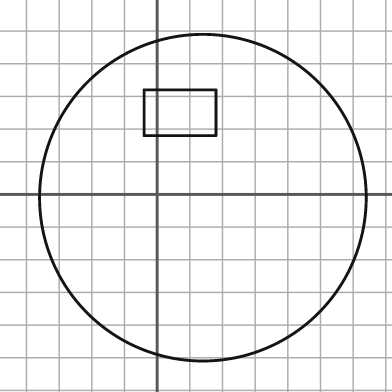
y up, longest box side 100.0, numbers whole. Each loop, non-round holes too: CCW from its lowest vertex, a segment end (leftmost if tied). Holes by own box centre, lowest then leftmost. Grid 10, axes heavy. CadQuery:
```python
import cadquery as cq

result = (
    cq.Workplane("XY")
    .moveTo(14.0, -1.0)
    .circle(50.0)
    .moveTo(-4.0, 18.0)
    .lineTo(18.0, 18.0)
    .lineTo(18.0, 32.0)
    .lineTo(-4.0, 32.0)
    .close()
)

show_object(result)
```